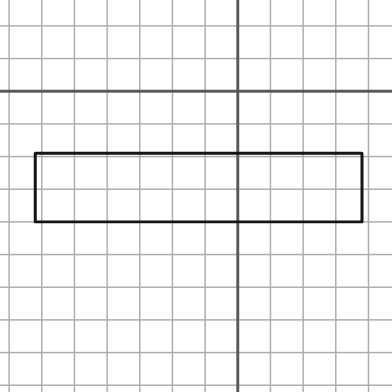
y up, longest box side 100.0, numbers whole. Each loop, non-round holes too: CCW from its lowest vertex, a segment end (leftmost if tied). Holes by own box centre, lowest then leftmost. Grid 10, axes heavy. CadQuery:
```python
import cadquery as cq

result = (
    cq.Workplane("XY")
    .moveTo(-62.0, -40.0)
    .lineTo(38.0, -40.0)
    .lineTo(38.0, -19.0)
    .lineTo(-62.0, -19.0)
    .close()
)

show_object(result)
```